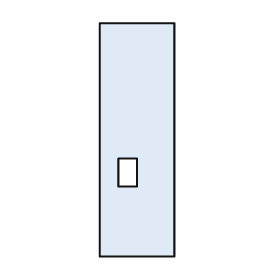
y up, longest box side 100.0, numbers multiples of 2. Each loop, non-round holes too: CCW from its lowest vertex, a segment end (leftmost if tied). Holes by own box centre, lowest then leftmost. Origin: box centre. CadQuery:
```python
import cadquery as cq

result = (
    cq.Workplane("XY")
    .moveTo(-16.0, -50.0)
    .lineTo(16.0, -50.0)
    .lineTo(16.0, 50.0)
    .lineTo(-16.0, 50.0)
    .close()
    .moveTo(-8.0, -20.0)
    .lineTo(0.0, -20.0)
    .lineTo(0.0, -8.0)
    .lineTo(-8.0, -8.0)
    .close()
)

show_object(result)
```